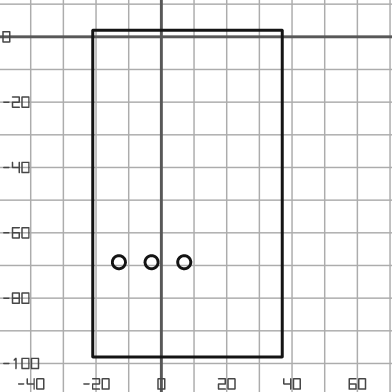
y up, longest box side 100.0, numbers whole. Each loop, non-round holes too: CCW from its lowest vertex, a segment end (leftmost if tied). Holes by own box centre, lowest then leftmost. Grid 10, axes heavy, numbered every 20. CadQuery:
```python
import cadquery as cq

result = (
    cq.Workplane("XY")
    .moveTo(-21.0, -98.0)
    .lineTo(37.0, -98.0)
    .lineTo(37.0, 2.0)
    .lineTo(-21.0, 2.0)
    .close()
    .moveTo(-13.0, -69.0)
    .circle(2.0)
    .moveTo(-3.0, -69.0)
    .circle(2.0)
    .moveTo(7.0, -69.0)
    .circle(2.0)
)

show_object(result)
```